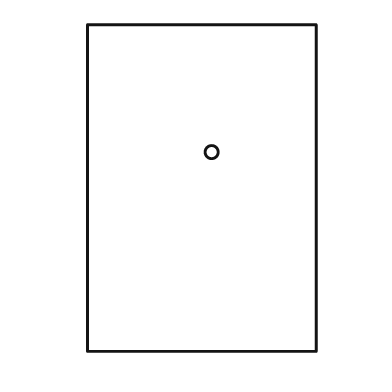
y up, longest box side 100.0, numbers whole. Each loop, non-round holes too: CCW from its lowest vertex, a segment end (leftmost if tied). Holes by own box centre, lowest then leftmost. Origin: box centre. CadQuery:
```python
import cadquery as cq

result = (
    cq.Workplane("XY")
    .moveTo(-35.0, -50.0)
    .lineTo(35.0, -50.0)
    .lineTo(35.0, 50.0)
    .lineTo(-35.0, 50.0)
    .close()
    .moveTo(3.0, 11.0)
    .circle(2.0)
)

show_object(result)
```